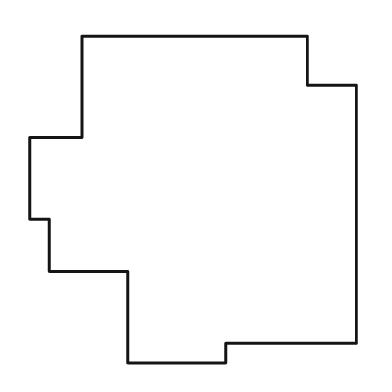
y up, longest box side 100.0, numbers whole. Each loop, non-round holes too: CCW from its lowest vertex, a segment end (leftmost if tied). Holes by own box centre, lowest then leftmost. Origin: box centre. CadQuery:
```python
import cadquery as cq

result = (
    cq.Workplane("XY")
    .moveTo(-20.0, -50.0)
    .lineTo(10.0, -50.0)
    .lineTo(10.0, -44.0)
    .lineTo(50.0, -44.0)
    .lineTo(50.0, 35.0)
    .lineTo(35.0, 35.0)
    .lineTo(35.0, 50.0)
    .lineTo(-34.0, 50.0)
    .lineTo(-34.0, 19.0)
    .lineTo(-50.0, 19.0)
    .lineTo(-50.0, -6.0)
    .lineTo(-44.0, -6.0)
    .lineTo(-44.0, -22.0)
    .lineTo(-20.0, -22.0)
    .close()
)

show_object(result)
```